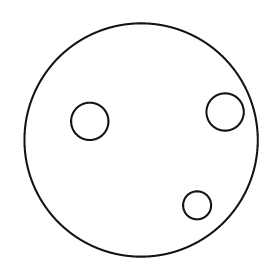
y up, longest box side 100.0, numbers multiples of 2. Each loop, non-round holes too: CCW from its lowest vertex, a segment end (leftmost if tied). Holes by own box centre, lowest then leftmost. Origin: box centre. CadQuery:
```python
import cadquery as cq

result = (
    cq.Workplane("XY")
    .moveTo(0.0, 0.0)
    .circle(50.0)
    .moveTo(24.0, -28.0)
    .circle(6.0)
    .moveTo(-22.0, 8.0)
    .circle(8.0)
    .moveTo(36.0, 12.0)
    .circle(8.0)
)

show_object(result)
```